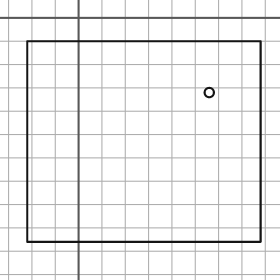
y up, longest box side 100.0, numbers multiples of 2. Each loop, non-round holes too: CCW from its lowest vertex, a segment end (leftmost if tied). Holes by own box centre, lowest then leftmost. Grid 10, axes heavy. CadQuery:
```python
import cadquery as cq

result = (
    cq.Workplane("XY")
    .moveTo(-22.0, -96.0)
    .lineTo(78.0, -96.0)
    .lineTo(78.0, -10.0)
    .lineTo(-22.0, -10.0)
    .close()
    .moveTo(56.0, -32.0)
    .circle(2.0)
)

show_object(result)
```